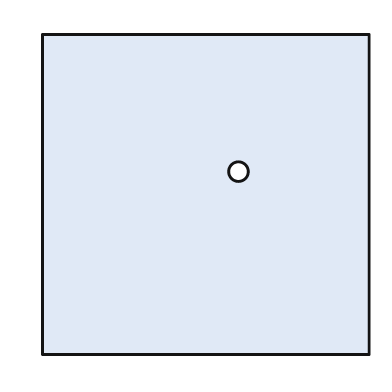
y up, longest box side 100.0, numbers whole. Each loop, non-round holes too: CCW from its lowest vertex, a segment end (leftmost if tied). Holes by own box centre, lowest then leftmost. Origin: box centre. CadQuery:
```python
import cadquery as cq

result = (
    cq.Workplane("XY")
    .moveTo(-50.0, -49.0)
    .lineTo(50.0, -49.0)
    .lineTo(50.0, 49.0)
    .lineTo(-50.0, 49.0)
    .close()
    .moveTo(10.0, 7.0)
    .circle(3.0)
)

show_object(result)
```